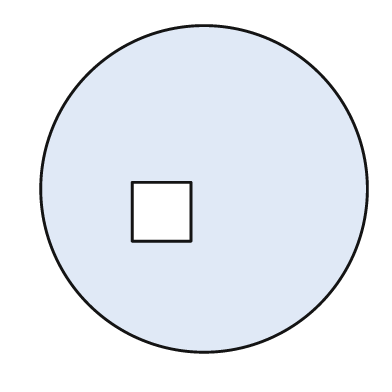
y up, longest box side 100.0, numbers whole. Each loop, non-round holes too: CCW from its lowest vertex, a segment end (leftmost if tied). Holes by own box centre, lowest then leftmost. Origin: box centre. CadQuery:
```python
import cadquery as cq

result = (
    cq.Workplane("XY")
    .moveTo(0.0, 0.0)
    .circle(50.0)
    .moveTo(-22.0, -16.0)
    .lineTo(-4.0, -16.0)
    .lineTo(-4.0, 2.0)
    .lineTo(-22.0, 2.0)
    .close()
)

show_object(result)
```